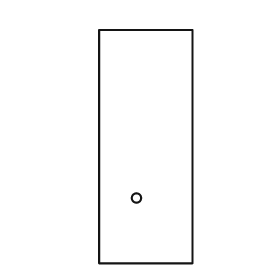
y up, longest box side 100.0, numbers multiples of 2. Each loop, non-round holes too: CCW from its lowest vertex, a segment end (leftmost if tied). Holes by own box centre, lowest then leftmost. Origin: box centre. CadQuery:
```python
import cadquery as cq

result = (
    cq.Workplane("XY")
    .moveTo(-20.0, -50.0)
    .lineTo(20.0, -50.0)
    .lineTo(20.0, 50.0)
    .lineTo(-20.0, 50.0)
    .close()
    .moveTo(-4.0, -22.0)
    .circle(2.0)
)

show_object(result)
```